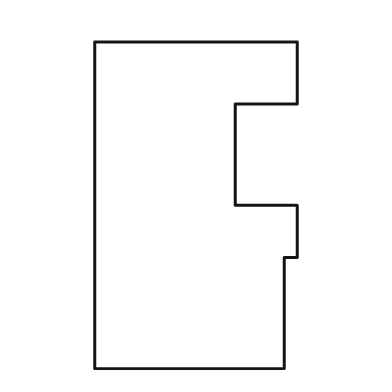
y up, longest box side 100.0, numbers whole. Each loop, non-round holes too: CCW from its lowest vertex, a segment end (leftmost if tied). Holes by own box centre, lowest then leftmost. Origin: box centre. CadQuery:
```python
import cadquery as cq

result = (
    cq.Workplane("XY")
    .moveTo(-31.0, -50.0)
    .lineTo(27.0, -50.0)
    .lineTo(27.0, -16.0)
    .lineTo(31.0, -16.0)
    .lineTo(31.0, 0.0)
    .lineTo(12.0, 0.0)
    .lineTo(12.0, 31.0)
    .lineTo(31.0, 31.0)
    .lineTo(31.0, 50.0)
    .lineTo(-31.0, 50.0)
    .close()
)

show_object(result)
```